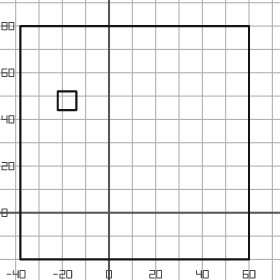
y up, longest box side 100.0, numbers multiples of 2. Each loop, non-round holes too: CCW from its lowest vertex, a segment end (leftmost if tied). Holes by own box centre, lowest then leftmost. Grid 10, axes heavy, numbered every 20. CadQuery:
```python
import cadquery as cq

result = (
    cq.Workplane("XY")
    .moveTo(-38.0, -20.0)
    .lineTo(60.0, -20.0)
    .lineTo(60.0, 80.0)
    .lineTo(-38.0, 80.0)
    .close()
    .moveTo(-22.0, 44.0)
    .lineTo(-14.0, 44.0)
    .lineTo(-14.0, 52.0)
    .lineTo(-22.0, 52.0)
    .close()
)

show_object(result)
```